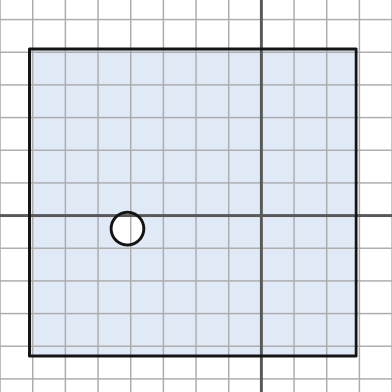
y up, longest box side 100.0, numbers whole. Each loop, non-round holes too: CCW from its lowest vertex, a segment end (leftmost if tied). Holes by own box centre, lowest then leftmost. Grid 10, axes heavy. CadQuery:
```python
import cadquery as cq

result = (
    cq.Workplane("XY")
    .moveTo(-71.0, -43.0)
    .lineTo(29.0, -43.0)
    .lineTo(29.0, 51.0)
    .lineTo(-71.0, 51.0)
    .close()
    .moveTo(-41.0, -4.0)
    .circle(5.0)
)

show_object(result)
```